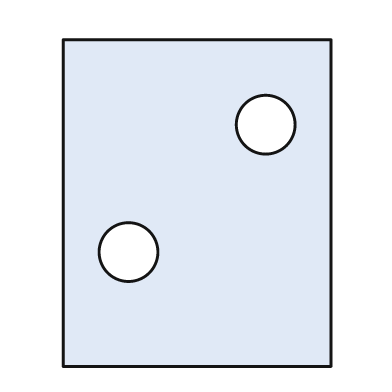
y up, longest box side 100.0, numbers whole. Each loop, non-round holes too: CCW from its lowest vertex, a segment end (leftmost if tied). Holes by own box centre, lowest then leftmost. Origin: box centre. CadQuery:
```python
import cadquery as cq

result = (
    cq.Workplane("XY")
    .moveTo(-41.0, -50.0)
    .lineTo(41.0, -50.0)
    .lineTo(41.0, 50.0)
    .lineTo(-41.0, 50.0)
    .close()
    .moveTo(-21.0, -15.0)
    .circle(9.0)
    .moveTo(21.0, 24.0)
    .circle(9.0)
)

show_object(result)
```